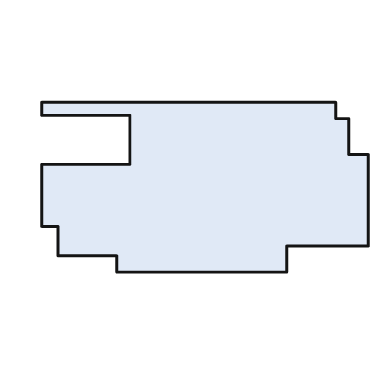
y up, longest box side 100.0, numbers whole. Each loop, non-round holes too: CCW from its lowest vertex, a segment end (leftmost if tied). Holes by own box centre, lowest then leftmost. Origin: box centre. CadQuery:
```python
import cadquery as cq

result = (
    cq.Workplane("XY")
    .moveTo(-27.0, -26.0)
    .lineTo(25.0, -26.0)
    .lineTo(25.0, -18.0)
    .lineTo(50.0, -18.0)
    .lineTo(50.0, 10.0)
    .lineTo(44.0, 10.0)
    .lineTo(44.0, 21.0)
    .lineTo(40.0, 21.0)
    .lineTo(40.0, 26.0)
    .lineTo(-50.0, 26.0)
    .lineTo(-50.0, 22.0)
    .lineTo(-23.0, 22.0)
    .lineTo(-23.0, 7.0)
    .lineTo(-50.0, 7.0)
    .lineTo(-50.0, -12.0)
    .lineTo(-45.0, -12.0)
    .lineTo(-45.0, -21.0)
    .lineTo(-27.0, -21.0)
    .close()
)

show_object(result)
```